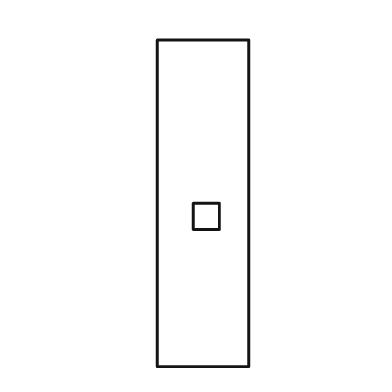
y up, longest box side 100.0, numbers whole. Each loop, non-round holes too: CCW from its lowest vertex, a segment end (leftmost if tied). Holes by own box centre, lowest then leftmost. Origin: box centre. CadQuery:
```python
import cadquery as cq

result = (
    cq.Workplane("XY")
    .moveTo(-14.0, -50.0)
    .lineTo(14.0, -50.0)
    .lineTo(14.0, 50.0)
    .lineTo(-14.0, 50.0)
    .close()
    .moveTo(-3.0, -8.0)
    .lineTo(5.0, -8.0)
    .lineTo(5.0, 0.0)
    .lineTo(-3.0, 0.0)
    .close()
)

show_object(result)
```